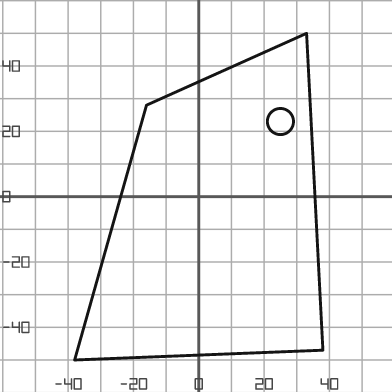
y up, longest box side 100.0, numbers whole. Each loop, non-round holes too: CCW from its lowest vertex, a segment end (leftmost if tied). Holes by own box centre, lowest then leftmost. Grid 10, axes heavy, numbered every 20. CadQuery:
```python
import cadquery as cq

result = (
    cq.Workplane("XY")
    .moveTo(-38.0, -50.0)
    .lineTo(38.0, -47.0)
    .lineTo(33.0, 50.0)
    .lineTo(-16.0, 28.0)
    .close()
    .moveTo(25.0, 23.0)
    .circle(4.0)
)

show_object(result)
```